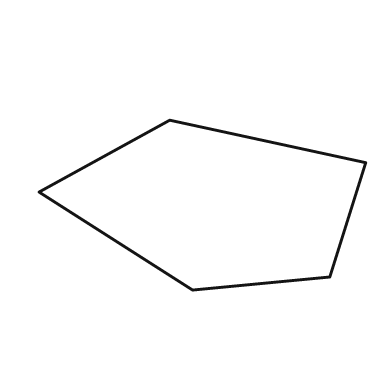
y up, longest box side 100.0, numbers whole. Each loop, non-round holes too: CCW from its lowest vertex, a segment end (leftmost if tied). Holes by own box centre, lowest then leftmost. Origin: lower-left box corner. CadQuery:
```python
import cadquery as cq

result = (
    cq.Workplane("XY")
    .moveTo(47.0, 0.0)
    .lineTo(89.0, 4.0)
    .lineTo(100.0, 39.0)
    .lineTo(40.0, 52.0)
    .lineTo(0.0, 30.0)
    .close()
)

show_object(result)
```